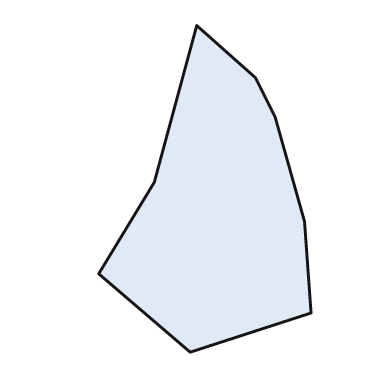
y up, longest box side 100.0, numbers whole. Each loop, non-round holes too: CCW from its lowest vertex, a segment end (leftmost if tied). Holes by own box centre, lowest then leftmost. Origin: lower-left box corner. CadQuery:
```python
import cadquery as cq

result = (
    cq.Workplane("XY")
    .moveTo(28.0, 0.0)
    .lineTo(65.0, 12.0)
    .lineTo(63.0, 40.0)
    .lineTo(54.0, 72.0)
    .lineTo(48.0, 84.0)
    .lineTo(30.0, 100.0)
    .lineTo(17.0, 52.0)
    .lineTo(0.0, 24.0)
    .close()
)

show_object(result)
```